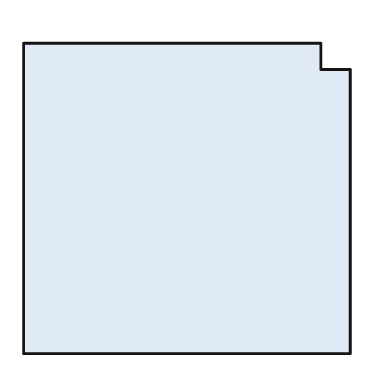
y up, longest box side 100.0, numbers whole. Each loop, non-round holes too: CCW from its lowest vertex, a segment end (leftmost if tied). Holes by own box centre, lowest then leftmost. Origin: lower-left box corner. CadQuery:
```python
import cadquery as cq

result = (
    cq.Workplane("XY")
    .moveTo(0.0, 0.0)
    .lineTo(100.0, 0.0)
    .lineTo(100.0, 87.0)
    .lineTo(91.0, 87.0)
    .lineTo(91.0, 95.0)
    .lineTo(0.0, 95.0)
    .close()
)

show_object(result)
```